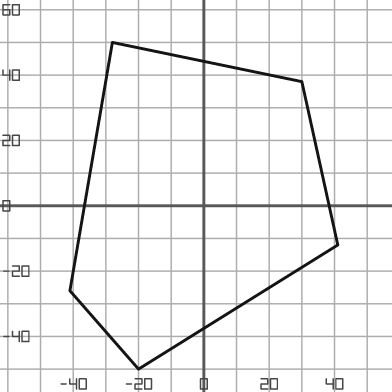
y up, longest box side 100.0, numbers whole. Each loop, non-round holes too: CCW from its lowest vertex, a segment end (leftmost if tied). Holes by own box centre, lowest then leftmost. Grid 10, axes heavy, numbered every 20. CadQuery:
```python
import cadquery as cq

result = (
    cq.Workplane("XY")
    .moveTo(-20.0, -50.0)
    .lineTo(41.0, -12.0)
    .lineTo(30.0, 38.0)
    .lineTo(-28.0, 50.0)
    .lineTo(-41.0, -26.0)
    .close()
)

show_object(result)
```